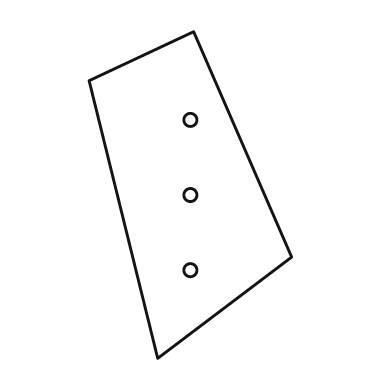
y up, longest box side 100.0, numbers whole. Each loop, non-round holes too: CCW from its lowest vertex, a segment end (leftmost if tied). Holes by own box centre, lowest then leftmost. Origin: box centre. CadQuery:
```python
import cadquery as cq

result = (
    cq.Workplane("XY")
    .moveTo(-10.0, -50.0)
    .lineTo(31.0, -19.0)
    .lineTo(1.0, 50.0)
    .lineTo(-31.0, 35.0)
    .close()
    .moveTo(0.0, -23.0)
    .circle(2.0)
    .moveTo(0.0, 0.0)
    .circle(2.0)
    .moveTo(0.0, 23.0)
    .circle(2.0)
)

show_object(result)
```